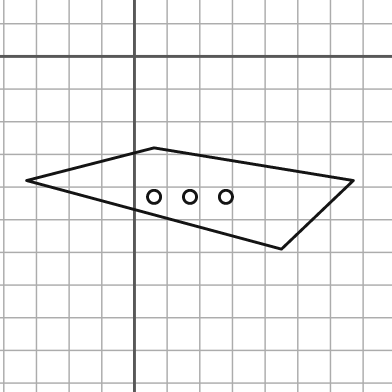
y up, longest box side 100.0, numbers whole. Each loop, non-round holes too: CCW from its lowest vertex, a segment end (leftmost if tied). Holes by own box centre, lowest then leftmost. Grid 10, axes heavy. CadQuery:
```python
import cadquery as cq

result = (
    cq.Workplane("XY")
    .moveTo(45.0, -59.0)
    .lineTo(67.0, -38.0)
    .lineTo(6.0, -28.0)
    .lineTo(-33.0, -38.0)
    .close()
    .moveTo(6.0, -43.0)
    .circle(2.0)
    .moveTo(17.0, -43.0)
    .circle(2.0)
    .moveTo(28.0, -43.0)
    .circle(2.0)
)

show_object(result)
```